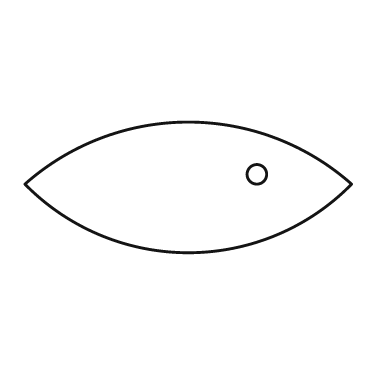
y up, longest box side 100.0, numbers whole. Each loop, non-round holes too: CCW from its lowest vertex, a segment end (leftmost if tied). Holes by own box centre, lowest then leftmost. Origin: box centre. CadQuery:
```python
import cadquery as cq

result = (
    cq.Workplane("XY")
    .moveTo(-50.0, 1.0)
    .threePointArc((0.0, -20.0), (50.0, 1.0))
    .threePointArc((0.0, 20.0), (-50.0, 1.0))
    .close()
    .moveTo(21.0, 4.0)
    .circle(3.0)
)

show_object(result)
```